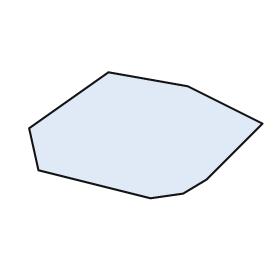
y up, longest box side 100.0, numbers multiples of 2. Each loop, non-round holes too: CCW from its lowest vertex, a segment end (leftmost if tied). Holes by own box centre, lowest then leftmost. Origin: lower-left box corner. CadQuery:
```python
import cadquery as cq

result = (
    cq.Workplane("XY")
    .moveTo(52.0, 0.0)
    .lineTo(66.0, 2.0)
    .lineTo(76.0, 8.0)
    .lineTo(100.0, 32.0)
    .lineTo(68.0, 48.0)
    .lineTo(34.0, 54.0)
    .lineTo(0.0, 30.0)
    .lineTo(4.0, 12.0)
    .close()
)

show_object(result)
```